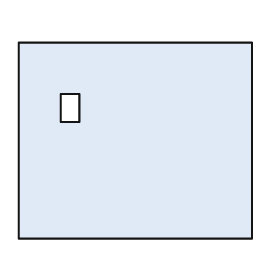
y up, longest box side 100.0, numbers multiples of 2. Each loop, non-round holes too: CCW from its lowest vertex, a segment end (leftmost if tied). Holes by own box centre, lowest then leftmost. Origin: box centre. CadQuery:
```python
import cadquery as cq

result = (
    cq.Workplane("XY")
    .moveTo(-50.0, -42.0)
    .lineTo(50.0, -42.0)
    .lineTo(50.0, 42.0)
    .lineTo(-50.0, 42.0)
    .close()
    .moveTo(-32.0, 8.0)
    .lineTo(-24.0, 8.0)
    .lineTo(-24.0, 20.0)
    .lineTo(-32.0, 20.0)
    .close()
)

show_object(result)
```